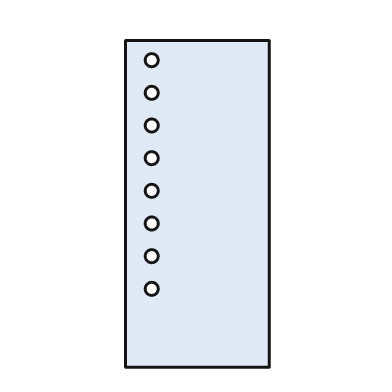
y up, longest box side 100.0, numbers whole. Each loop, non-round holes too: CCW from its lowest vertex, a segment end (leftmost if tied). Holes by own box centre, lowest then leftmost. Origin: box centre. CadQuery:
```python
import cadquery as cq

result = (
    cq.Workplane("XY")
    .moveTo(-22.0, -50.0)
    .lineTo(22.0, -50.0)
    .lineTo(22.0, 50.0)
    .lineTo(-22.0, 50.0)
    .close()
    .moveTo(-14.0, -26.0)
    .circle(2.0)
    .moveTo(-14.0, -16.0)
    .circle(2.0)
    .moveTo(-14.0, -6.0)
    .circle(2.0)
    .moveTo(-14.0, 4.0)
    .circle(2.0)
    .moveTo(-14.0, 14.0)
    .circle(2.0)
    .moveTo(-14.0, 24.0)
    .circle(2.0)
    .moveTo(-14.0, 34.0)
    .circle(2.0)
    .moveTo(-14.0, 44.0)
    .circle(2.0)
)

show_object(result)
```